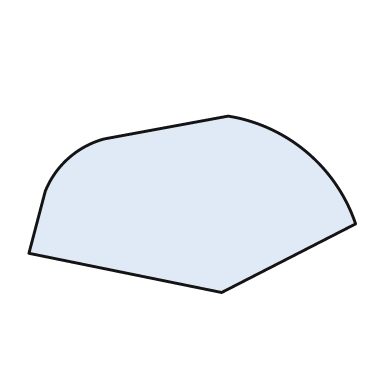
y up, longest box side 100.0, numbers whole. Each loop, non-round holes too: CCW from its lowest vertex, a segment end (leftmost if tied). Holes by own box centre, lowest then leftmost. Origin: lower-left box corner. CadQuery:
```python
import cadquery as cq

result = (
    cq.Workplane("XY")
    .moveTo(59.0, 0.0)
    .lineTo(100.0, 21.0)
    .threePointArc((85.0, 43.0), (61.0, 54.0))
    .lineTo(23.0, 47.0)
    .threePointArc((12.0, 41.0), (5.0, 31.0))
    .lineTo(0.0, 12.0)
    .close()
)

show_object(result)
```